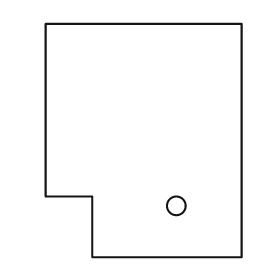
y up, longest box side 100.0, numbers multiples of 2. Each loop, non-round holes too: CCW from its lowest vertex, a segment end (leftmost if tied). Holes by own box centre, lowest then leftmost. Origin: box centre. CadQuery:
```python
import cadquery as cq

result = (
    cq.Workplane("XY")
    .moveTo(-22.0, -50.0)
    .lineTo(42.0, -50.0)
    .lineTo(42.0, 50.0)
    .lineTo(-42.0, 50.0)
    .lineTo(-42.0, -24.0)
    .lineTo(-22.0, -24.0)
    .close()
    .moveTo(14.0, -28.0)
    .circle(4.0)
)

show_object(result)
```